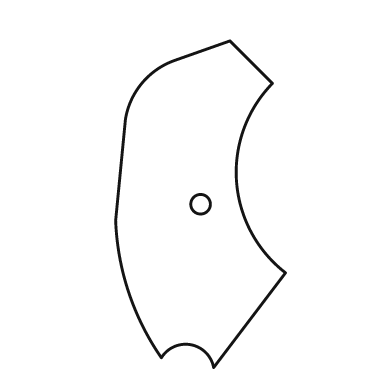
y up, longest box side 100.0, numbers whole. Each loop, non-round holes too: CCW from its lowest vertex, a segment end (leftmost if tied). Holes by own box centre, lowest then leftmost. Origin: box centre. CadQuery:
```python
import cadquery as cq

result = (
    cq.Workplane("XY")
    .moveTo(4.0, -50.0)
    .lineTo(26.0, -21.0)
    .threePointArc((11.0, 7.0), (22.0, 37.0))
    .lineTo(9.0, 50.0)
    .lineTo(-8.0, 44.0)
    .threePointArc((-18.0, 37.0), (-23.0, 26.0))
    .lineTo(-26.0, -5.0)
    .threePointArc((-22.0, -27.0), (-12.0, -47.0))
    .threePointArc((-3.0, -43.0), (4.0, -50.0))
    .close()
    .moveTo(0.0, 0.0)
    .circle(3.0)
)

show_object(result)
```